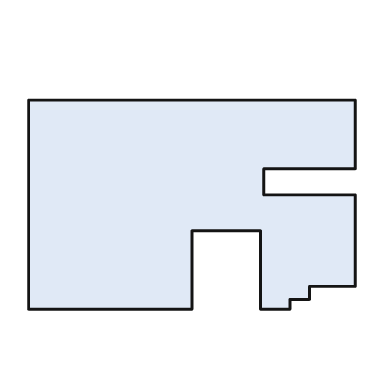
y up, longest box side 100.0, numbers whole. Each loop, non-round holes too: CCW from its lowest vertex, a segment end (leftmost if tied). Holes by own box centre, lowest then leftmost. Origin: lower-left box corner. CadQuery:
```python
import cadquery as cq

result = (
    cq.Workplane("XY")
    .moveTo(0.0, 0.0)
    .lineTo(50.0, 0.0)
    .lineTo(50.0, 24.0)
    .lineTo(71.0, 24.0)
    .lineTo(71.0, 0.0)
    .lineTo(80.0, 0.0)
    .lineTo(80.0, 3.0)
    .lineTo(86.0, 3.0)
    .lineTo(86.0, 7.0)
    .lineTo(100.0, 7.0)
    .lineTo(100.0, 35.0)
    .lineTo(72.0, 35.0)
    .lineTo(72.0, 43.0)
    .lineTo(100.0, 43.0)
    .lineTo(100.0, 64.0)
    .lineTo(0.0, 64.0)
    .close()
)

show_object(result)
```